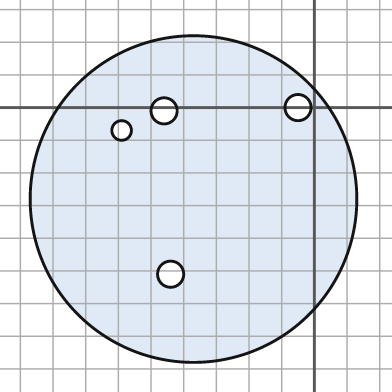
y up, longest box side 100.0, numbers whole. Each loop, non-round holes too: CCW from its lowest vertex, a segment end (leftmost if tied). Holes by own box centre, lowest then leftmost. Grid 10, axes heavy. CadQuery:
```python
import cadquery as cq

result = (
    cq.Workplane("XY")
    .moveTo(-37.0, -28.0)
    .circle(50.0)
    .moveTo(-44.0, -51.0)
    .circle(4.0)
    .moveTo(-59.0, -7.0)
    .circle(3.0)
    .moveTo(-46.0, -1.0)
    .circle(4.0)
    .moveTo(-5.0, 0.0)
    .circle(4.0)
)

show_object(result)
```